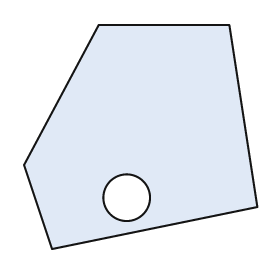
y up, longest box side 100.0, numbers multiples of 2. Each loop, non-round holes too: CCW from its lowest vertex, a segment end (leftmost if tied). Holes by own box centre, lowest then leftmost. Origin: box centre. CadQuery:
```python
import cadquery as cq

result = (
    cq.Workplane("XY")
    .moveTo(-38.0, -48.0)
    .lineTo(50.0, -30.0)
    .lineTo(38.0, 48.0)
    .lineTo(-18.0, 48.0)
    .lineTo(-50.0, -12.0)
    .close()
    .moveTo(-6.0, -26.0)
    .circle(10.0)
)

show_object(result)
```